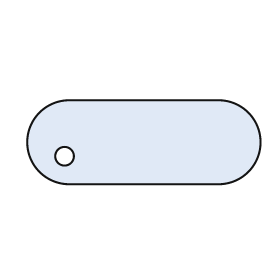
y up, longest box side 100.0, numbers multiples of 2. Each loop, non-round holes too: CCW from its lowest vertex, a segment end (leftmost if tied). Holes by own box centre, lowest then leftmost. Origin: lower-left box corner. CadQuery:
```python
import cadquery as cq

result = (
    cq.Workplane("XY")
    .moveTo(18.0, 0.0)
    .lineTo(82.0, 0.0)
    .threePointArc((100.0, 18.0), (82.0, 36.0))
    .lineTo(18.0, 36.0)
    .threePointArc((0.0, 18.0), (18.0, 0.0))
    .close()
    .moveTo(16.0, 12.0)
    .circle(4.0)
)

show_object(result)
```